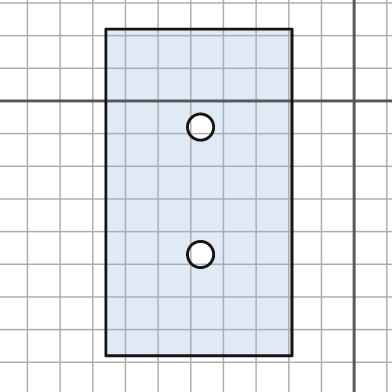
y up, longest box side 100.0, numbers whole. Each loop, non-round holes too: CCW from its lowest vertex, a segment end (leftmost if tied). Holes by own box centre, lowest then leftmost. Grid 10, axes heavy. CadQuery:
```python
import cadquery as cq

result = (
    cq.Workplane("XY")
    .moveTo(-76.0, -78.0)
    .lineTo(-19.0, -78.0)
    .lineTo(-19.0, 22.0)
    .lineTo(-76.0, 22.0)
    .close()
    .moveTo(-47.0, -47.0)
    .circle(4.0)
    .moveTo(-47.0, -8.0)
    .circle(4.0)
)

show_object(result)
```